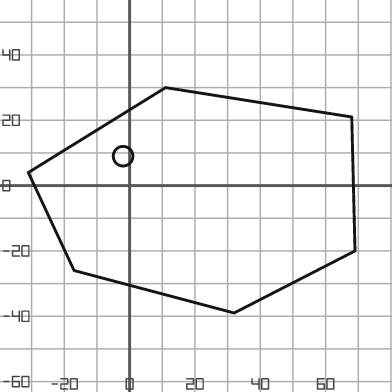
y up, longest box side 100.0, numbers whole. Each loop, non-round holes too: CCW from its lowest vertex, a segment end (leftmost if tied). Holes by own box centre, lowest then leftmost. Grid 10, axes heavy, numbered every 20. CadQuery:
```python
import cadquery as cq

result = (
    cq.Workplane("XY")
    .moveTo(32.0, -39.0)
    .lineTo(69.0, -20.0)
    .lineTo(68.0, 21.0)
    .lineTo(11.0, 30.0)
    .lineTo(-31.0, 4.0)
    .lineTo(-17.0, -26.0)
    .close()
    .moveTo(-2.0, 9.0)
    .circle(3.0)
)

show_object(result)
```